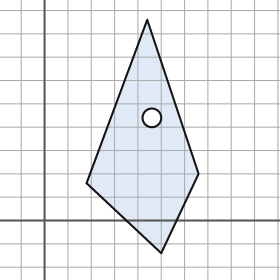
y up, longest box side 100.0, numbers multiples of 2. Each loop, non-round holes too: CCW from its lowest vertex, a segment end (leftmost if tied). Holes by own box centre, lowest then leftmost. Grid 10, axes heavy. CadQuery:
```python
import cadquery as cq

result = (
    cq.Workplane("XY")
    .moveTo(50.0, -14.0)
    .lineTo(66.0, 20.0)
    .lineTo(44.0, 86.0)
    .lineTo(18.0, 16.0)
    .close()
    .moveTo(46.0, 44.0)
    .circle(4.0)
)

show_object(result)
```